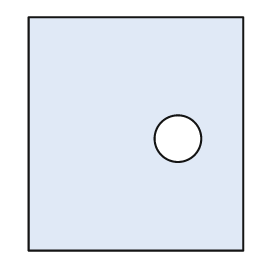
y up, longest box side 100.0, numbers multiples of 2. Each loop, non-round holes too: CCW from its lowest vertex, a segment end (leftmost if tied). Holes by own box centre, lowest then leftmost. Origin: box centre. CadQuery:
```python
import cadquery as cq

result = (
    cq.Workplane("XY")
    .moveTo(-46.0, -50.0)
    .lineTo(46.0, -50.0)
    .lineTo(46.0, 50.0)
    .lineTo(-46.0, 50.0)
    .close()
    .moveTo(18.0, -2.0)
    .circle(10.0)
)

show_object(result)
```